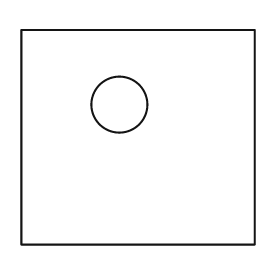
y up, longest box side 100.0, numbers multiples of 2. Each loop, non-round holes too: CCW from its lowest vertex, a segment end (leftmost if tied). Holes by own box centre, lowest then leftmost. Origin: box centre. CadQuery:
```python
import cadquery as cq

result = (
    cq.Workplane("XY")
    .moveTo(-50.0, -46.0)
    .lineTo(50.0, -46.0)
    .lineTo(50.0, 46.0)
    .lineTo(-50.0, 46.0)
    .close()
    .moveTo(-8.0, 14.0)
    .circle(12.0)
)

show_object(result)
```